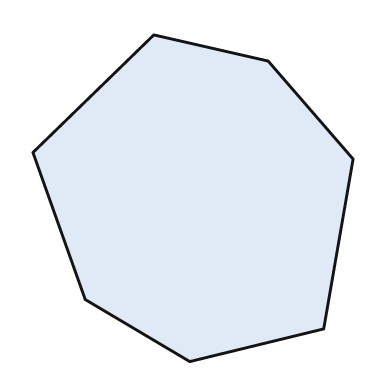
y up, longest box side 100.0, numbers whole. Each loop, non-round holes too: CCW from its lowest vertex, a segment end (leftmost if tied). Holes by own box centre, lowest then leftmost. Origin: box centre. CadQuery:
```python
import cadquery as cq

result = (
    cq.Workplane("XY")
    .moveTo(-1.0, -50.0)
    .lineTo(40.0, -40.0)
    .lineTo(49.0, 12.0)
    .lineTo(23.0, 42.0)
    .lineTo(-12.0, 50.0)
    .lineTo(-49.0, 14.0)
    .lineTo(-33.0, -31.0)
    .close()
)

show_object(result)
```